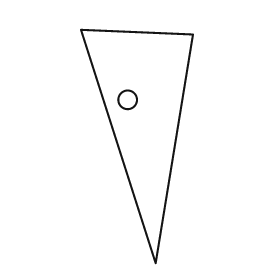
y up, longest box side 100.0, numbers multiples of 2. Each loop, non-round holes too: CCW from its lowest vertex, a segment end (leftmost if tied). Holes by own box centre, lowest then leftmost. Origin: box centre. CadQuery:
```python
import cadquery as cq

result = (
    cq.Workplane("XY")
    .moveTo(8.0, -50.0)
    .lineTo(24.0, 48.0)
    .lineTo(-24.0, 50.0)
    .close()
    .moveTo(-4.0, 20.0)
    .circle(4.0)
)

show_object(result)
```